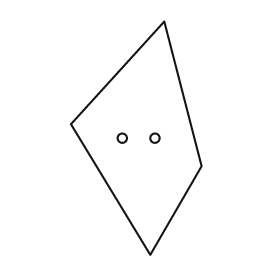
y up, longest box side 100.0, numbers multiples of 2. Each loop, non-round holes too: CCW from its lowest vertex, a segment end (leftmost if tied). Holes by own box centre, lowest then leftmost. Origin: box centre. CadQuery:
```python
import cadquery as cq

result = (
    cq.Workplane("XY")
    .moveTo(6.0, -50.0)
    .lineTo(28.0, -12.0)
    .lineTo(12.0, 50.0)
    .lineTo(-28.0, 6.0)
    .close()
    .moveTo(-6.0, 0.0)
    .circle(2.0)
    .moveTo(8.0, 0.0)
    .circle(2.0)
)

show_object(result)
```